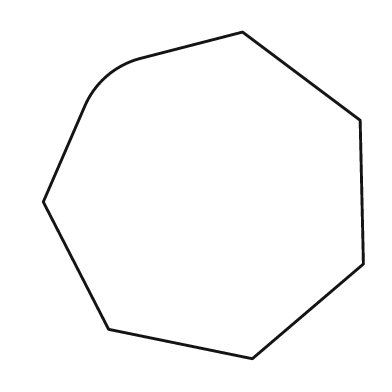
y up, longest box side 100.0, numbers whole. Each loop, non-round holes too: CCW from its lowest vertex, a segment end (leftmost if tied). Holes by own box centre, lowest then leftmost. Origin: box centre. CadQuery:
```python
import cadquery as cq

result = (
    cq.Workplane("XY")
    .moveTo(15.0, -50.0)
    .lineTo(49.0, -21.0)
    .lineTo(48.0, 23.0)
    .lineTo(12.0, 50.0)
    .lineTo(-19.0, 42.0)
    .threePointArc((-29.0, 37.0), (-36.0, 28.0))
    .lineTo(-49.0, -2.0)
    .lineTo(-29.0, -41.0)
    .close()
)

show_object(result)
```